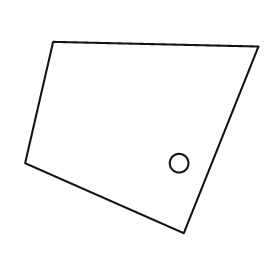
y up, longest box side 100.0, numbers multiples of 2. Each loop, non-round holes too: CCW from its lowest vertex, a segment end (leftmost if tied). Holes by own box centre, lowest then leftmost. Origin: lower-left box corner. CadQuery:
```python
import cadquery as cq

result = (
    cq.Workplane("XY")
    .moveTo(68.0, 0.0)
    .lineTo(100.0, 80.0)
    .lineTo(12.0, 82.0)
    .lineTo(0.0, 30.0)
    .close()
    .moveTo(66.0, 30.0)
    .circle(4.0)
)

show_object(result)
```